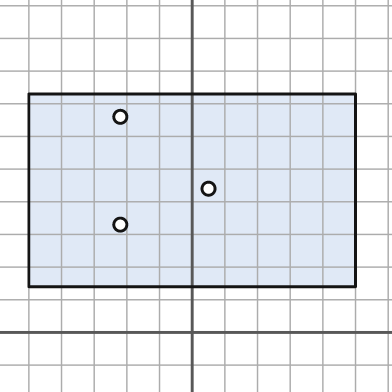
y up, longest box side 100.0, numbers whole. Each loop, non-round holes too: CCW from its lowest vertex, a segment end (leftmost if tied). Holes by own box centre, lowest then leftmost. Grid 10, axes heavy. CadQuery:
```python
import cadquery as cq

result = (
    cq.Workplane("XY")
    .moveTo(-50.0, 14.0)
    .lineTo(50.0, 14.0)
    .lineTo(50.0, 73.0)
    .lineTo(-50.0, 73.0)
    .close()
    .moveTo(-22.0, 33.0)
    .circle(2.0)
    .moveTo(5.0, 44.0)
    .circle(2.0)
    .moveTo(-22.0, 66.0)
    .circle(2.0)
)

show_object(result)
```